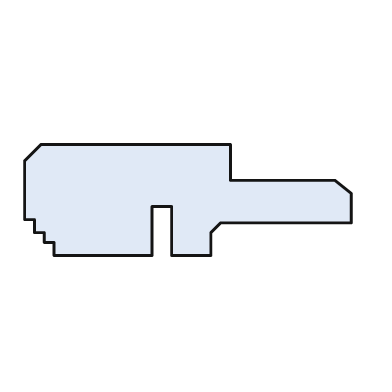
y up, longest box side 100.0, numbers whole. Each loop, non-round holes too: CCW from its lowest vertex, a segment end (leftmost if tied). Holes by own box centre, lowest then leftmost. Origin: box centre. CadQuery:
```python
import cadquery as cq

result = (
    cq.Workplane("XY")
    .moveTo(-41.0, -17.0)
    .lineTo(-11.0, -17.0)
    .lineTo(-11.0, -2.0)
    .lineTo(-5.0, -2.0)
    .lineTo(-5.0, -17.0)
    .lineTo(7.0, -17.0)
    .lineTo(7.0, -10.0)
    .lineTo(10.0, -7.0)
    .lineTo(50.0, -7.0)
    .lineTo(50.0, 2.0)
    .lineTo(45.0, 6.0)
    .lineTo(13.0, 6.0)
    .lineTo(13.0, 17.0)
    .lineTo(-45.0, 17.0)
    .lineTo(-50.0, 12.0)
    .lineTo(-50.0, -6.0)
    .lineTo(-47.0, -6.0)
    .lineTo(-47.0, -10.0)
    .lineTo(-44.0, -10.0)
    .lineTo(-44.0, -13.0)
    .lineTo(-41.0, -13.0)
    .close()
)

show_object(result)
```